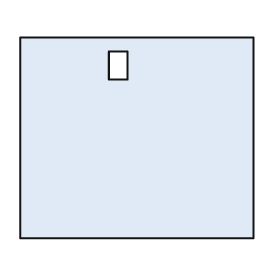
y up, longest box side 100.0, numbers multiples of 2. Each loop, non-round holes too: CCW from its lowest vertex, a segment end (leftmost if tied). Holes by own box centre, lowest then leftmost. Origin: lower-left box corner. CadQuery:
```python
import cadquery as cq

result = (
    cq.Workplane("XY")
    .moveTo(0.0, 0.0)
    .lineTo(100.0, 0.0)
    .lineTo(100.0, 86.0)
    .lineTo(0.0, 86.0)
    .close()
    .moveTo(38.0, 68.0)
    .lineTo(46.0, 68.0)
    .lineTo(46.0, 80.0)
    .lineTo(38.0, 80.0)
    .close()
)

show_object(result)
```